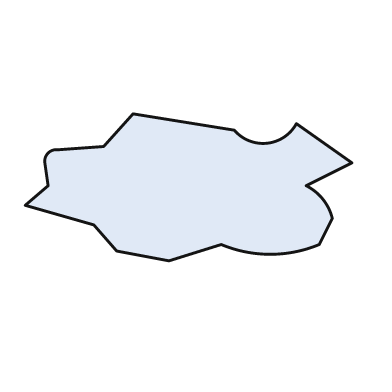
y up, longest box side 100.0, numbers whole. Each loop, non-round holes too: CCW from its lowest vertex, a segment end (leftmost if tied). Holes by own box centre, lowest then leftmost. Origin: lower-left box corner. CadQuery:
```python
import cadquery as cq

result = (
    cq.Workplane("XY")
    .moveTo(44.0, 0.0)
    .lineTo(60.0, 5.0)
    .threePointArc((75.0, 2.0), (90.0, 5.0))
    .lineTo(94.0, 13.0)
    .threePointArc((91.0, 19.0), (86.0, 23.0))
    .lineTo(100.0, 30.0)
    .lineTo(83.0, 42.0)
    .threePointArc((74.0, 36.0), (64.0, 40.0))
    .lineTo(33.0, 45.0)
    .lineTo(24.0, 35.0)
    .lineTo(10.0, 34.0)
    .threePointArc((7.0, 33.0), (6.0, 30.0))
    .lineTo(7.0, 23.0)
    .lineTo(0.0, 17.0)
    .lineTo(21.0, 11.0)
    .lineTo(28.0, 3.0)
    .close()
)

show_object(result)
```